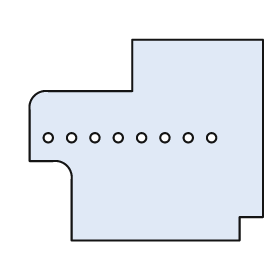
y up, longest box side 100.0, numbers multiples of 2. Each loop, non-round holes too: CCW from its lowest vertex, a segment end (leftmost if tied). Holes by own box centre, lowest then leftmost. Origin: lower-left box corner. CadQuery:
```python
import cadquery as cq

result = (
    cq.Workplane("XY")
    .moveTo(18.0, 0.0)
    .lineTo(90.0, 0.0)
    .lineTo(90.0, 10.0)
    .lineTo(100.0, 10.0)
    .lineTo(100.0, 86.0)
    .lineTo(44.0, 86.0)
    .lineTo(44.0, 64.0)
    .lineTo(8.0, 64.0)
    .threePointArc((2.0, 62.0), (0.0, 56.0))
    .lineTo(0.0, 34.0)
    .lineTo(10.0, 34.0)
    .threePointArc((16.0, 32.0), (18.0, 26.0))
    .close()
    .moveTo(8.0, 44.0)
    .circle(2.0)
    .moveTo(18.0, 44.0)
    .circle(2.0)
    .moveTo(28.0, 44.0)
    .circle(2.0)
    .moveTo(38.0, 44.0)
    .circle(2.0)
    .moveTo(48.0, 44.0)
    .circle(2.0)
    .moveTo(58.0, 44.0)
    .circle(2.0)
    .moveTo(68.0, 44.0)
    .circle(2.0)
    .moveTo(78.0, 44.0)
    .circle(2.0)
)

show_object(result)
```